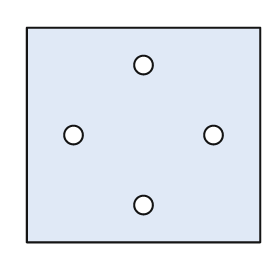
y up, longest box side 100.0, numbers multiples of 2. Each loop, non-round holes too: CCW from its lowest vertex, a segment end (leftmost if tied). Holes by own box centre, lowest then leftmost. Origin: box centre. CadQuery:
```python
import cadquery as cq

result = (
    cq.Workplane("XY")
    .moveTo(-50.0, -46.0)
    .lineTo(50.0, -46.0)
    .lineTo(50.0, 46.0)
    .lineTo(-50.0, 46.0)
    .close()
    .moveTo(0.0, -30.0)
    .circle(4.0)
    .moveTo(-30.0, 0.0)
    .circle(4.0)
    .moveTo(30.0, 0.0)
    .circle(4.0)
    .moveTo(0.0, 30.0)
    .circle(4.0)
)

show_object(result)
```